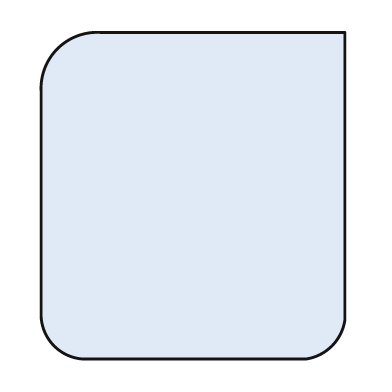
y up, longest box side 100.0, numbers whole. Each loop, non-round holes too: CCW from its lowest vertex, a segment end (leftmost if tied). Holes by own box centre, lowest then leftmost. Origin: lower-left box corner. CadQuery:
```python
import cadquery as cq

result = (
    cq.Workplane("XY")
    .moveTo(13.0, 0.0)
    .lineTo(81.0, 0.0)
    .threePointArc((89.0, 4.0), (93.0, 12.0))
    .lineTo(93.0, 100.0)
    .lineTo(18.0, 100.0)
    .threePointArc((5.0, 95.0), (0.0, 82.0))
    .lineTo(0.0, 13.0)
    .threePointArc((4.0, 4.0), (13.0, 0.0))
    .close()
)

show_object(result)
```